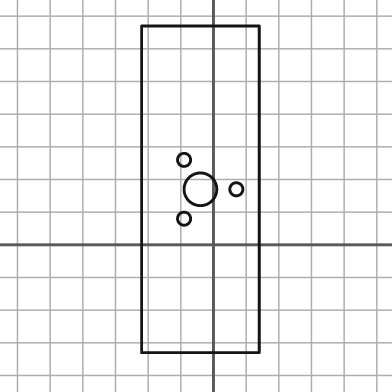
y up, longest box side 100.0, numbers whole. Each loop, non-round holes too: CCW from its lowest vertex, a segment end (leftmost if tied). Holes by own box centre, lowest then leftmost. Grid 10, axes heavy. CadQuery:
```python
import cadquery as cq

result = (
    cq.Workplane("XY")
    .moveTo(-22.0, -33.0)
    .lineTo(14.0, -33.0)
    .lineTo(14.0, 67.0)
    .lineTo(-22.0, 67.0)
    .close()
    .moveTo(-9.0, 8.0)
    .circle(2.0)
    .moveTo(-4.0, 17.0)
    .circle(5.0)
    .moveTo(7.0, 17.0)
    .circle(2.0)
    .moveTo(-9.0, 26.0)
    .circle(2.0)
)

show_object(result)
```